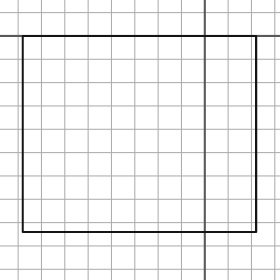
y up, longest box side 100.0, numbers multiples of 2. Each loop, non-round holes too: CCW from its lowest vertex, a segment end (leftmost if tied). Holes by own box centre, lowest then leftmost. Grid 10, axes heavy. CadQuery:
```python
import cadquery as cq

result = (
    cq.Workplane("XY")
    .moveTo(-78.0, -84.0)
    .lineTo(22.0, -84.0)
    .lineTo(22.0, 0.0)
    .lineTo(-78.0, 0.0)
    .close()
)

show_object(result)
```